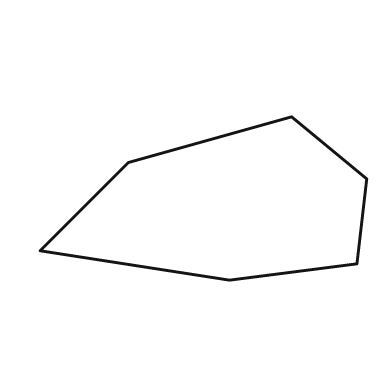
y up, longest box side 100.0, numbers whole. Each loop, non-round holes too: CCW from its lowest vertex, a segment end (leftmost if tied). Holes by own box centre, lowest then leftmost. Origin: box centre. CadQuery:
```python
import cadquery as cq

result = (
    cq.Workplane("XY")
    .moveTo(8.0, -25.0)
    .lineTo(47.0, -20.0)
    .lineTo(50.0, 6.0)
    .lineTo(27.0, 25.0)
    .lineTo(-23.0, 11.0)
    .lineTo(-50.0, -16.0)
    .close()
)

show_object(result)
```